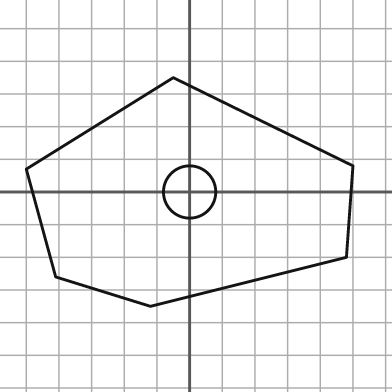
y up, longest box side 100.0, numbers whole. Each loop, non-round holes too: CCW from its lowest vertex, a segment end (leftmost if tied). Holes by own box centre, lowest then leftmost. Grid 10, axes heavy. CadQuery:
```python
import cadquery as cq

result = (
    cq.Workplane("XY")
    .moveTo(-12.0, -35.0)
    .lineTo(48.0, -20.0)
    .lineTo(50.0, 8.0)
    .lineTo(-5.0, 35.0)
    .lineTo(-50.0, 7.0)
    .lineTo(-41.0, -26.0)
    .close()
    .moveTo(0.0, 0.0)
    .circle(8.0)
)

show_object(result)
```